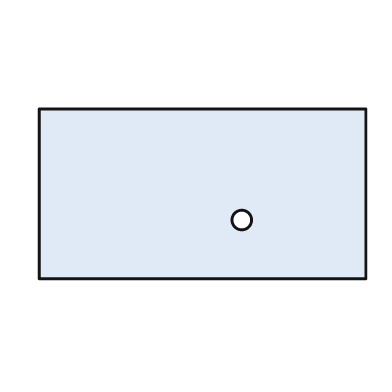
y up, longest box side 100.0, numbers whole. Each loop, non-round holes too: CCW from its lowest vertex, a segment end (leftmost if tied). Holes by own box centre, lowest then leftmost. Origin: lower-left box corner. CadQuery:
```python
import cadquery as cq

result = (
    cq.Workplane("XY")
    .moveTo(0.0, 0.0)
    .lineTo(100.0, 0.0)
    .lineTo(100.0, 52.0)
    .lineTo(0.0, 52.0)
    .close()
    .moveTo(62.0, 18.0)
    .circle(3.0)
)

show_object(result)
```